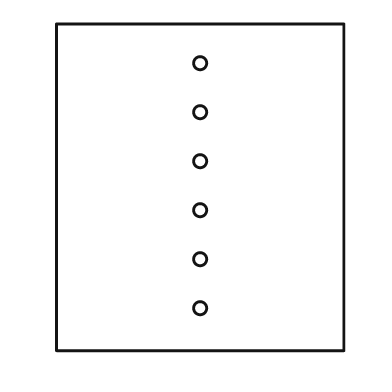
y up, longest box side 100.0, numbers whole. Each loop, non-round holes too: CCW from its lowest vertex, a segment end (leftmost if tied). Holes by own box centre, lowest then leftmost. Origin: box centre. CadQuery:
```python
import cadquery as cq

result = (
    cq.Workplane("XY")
    .moveTo(-44.0, -50.0)
    .lineTo(44.0, -50.0)
    .lineTo(44.0, 50.0)
    .lineTo(-44.0, 50.0)
    .close()
    .moveTo(0.0, -37.0)
    .circle(2.0)
    .moveTo(0.0, -22.0)
    .circle(2.0)
    .moveTo(0.0, -7.0)
    .circle(2.0)
    .moveTo(0.0, 8.0)
    .circle(2.0)
    .moveTo(0.0, 23.0)
    .circle(2.0)
    .moveTo(0.0, 38.0)
    .circle(2.0)
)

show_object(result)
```